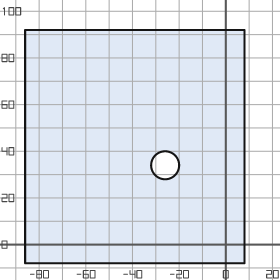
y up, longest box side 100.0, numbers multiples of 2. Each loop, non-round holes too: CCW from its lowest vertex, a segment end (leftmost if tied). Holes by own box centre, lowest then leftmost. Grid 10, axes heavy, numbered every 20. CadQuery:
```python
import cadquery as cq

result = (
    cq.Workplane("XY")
    .moveTo(-86.0, -8.0)
    .lineTo(8.0, -8.0)
    .lineTo(8.0, 92.0)
    .lineTo(-86.0, 92.0)
    .close()
    .moveTo(-26.0, 34.0)
    .circle(6.0)
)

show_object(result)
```